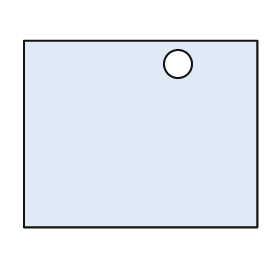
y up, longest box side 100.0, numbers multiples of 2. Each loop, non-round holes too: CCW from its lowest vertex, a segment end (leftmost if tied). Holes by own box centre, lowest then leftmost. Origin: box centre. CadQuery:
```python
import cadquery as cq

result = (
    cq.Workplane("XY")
    .moveTo(-50.0, -40.0)
    .lineTo(50.0, -40.0)
    .lineTo(50.0, 40.0)
    .lineTo(-50.0, 40.0)
    .close()
    .moveTo(16.0, 30.0)
    .circle(6.0)
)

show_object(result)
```